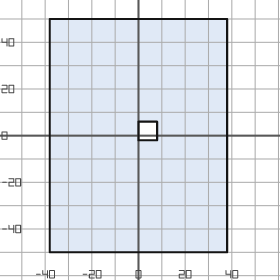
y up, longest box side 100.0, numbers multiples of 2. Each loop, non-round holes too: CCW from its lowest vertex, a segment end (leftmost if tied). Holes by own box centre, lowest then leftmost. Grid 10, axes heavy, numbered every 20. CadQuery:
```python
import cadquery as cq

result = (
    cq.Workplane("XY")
    .moveTo(-38.0, -50.0)
    .lineTo(38.0, -50.0)
    .lineTo(38.0, 50.0)
    .lineTo(-38.0, 50.0)
    .close()
    .moveTo(0.0, -2.0)
    .lineTo(8.0, -2.0)
    .lineTo(8.0, 6.0)
    .lineTo(0.0, 6.0)
    .close()
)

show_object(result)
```